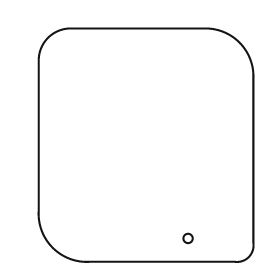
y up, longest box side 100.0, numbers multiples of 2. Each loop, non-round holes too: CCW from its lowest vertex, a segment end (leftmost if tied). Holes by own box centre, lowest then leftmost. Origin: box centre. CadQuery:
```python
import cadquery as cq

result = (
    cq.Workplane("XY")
    .moveTo(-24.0, -50.0)
    .lineTo(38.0, -50.0)
    .threePointArc((44.0, -48.0), (46.0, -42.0))
    .lineTo(46.0, 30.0)
    .threePointArc((40.0, 44.0), (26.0, 50.0))
    .lineTo(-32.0, 50.0)
    .threePointArc((-42.0, 46.0), (-46.0, 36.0))
    .lineTo(-46.0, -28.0)
    .threePointArc((-40.0, -44.0), (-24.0, -50.0))
    .close()
    .moveTo(18.0, -40.0)
    .circle(2.0)
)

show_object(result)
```